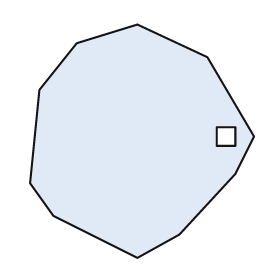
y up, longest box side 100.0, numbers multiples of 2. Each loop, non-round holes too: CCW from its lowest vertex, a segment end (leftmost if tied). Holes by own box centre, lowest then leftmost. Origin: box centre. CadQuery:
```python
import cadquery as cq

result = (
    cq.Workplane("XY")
    .moveTo(-2.0, -50.0)
    .lineTo(16.0, -40.0)
    .lineTo(40.0, -14.0)
    .lineTo(48.0, 2.0)
    .lineTo(28.0, 36.0)
    .lineTo(-2.0, 50.0)
    .lineTo(-28.0, 42.0)
    .lineTo(-44.0, 22.0)
    .lineTo(-48.0, -18.0)
    .lineTo(-38.0, -32.0)
    .close()
    .moveTo(32.0, -2.0)
    .lineTo(40.0, -2.0)
    .lineTo(40.0, 6.0)
    .lineTo(32.0, 6.0)
    .close()
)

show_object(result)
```